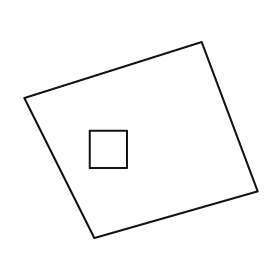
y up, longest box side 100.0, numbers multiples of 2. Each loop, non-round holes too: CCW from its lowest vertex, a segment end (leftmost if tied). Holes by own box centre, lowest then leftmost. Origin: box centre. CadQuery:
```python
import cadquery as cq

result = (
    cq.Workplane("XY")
    .moveTo(-20.0, -42.0)
    .lineTo(50.0, -22.0)
    .lineTo(26.0, 42.0)
    .lineTo(-50.0, 18.0)
    .close()
    .moveTo(-22.0, -12.0)
    .lineTo(-6.0, -12.0)
    .lineTo(-6.0, 4.0)
    .lineTo(-22.0, 4.0)
    .close()
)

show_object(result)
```